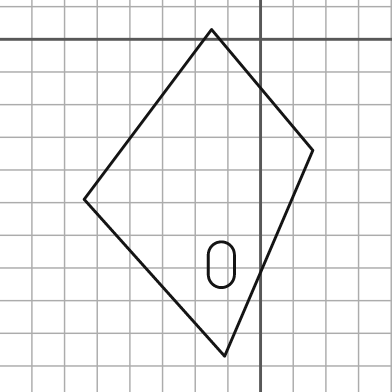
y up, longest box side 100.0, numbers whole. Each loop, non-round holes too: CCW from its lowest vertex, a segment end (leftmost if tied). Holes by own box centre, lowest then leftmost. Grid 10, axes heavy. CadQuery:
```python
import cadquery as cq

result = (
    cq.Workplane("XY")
    .moveTo(-11.0, -97.0)
    .lineTo(16.0, -34.0)
    .lineTo(-15.0, 3.0)
    .lineTo(-54.0, -49.0)
    .close()
    .moveTo(-16.0, -72.0)
    .threePointArc((-12.0, -76.0), (-8.0, -72.0))
    .lineTo(-8.0, -66.0)
    .threePointArc((-12.0, -62.0), (-16.0, -66.0))
    .close()
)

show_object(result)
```